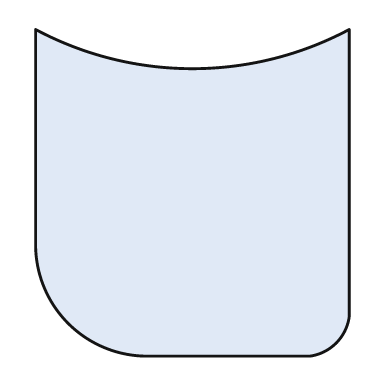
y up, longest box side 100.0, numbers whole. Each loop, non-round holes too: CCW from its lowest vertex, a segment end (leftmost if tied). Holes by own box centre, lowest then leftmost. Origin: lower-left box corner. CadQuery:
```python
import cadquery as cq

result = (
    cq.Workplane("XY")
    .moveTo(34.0, 0.0)
    .lineTo(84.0, 0.0)
    .threePointArc((92.0, 4.0), (96.0, 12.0))
    .lineTo(96.0, 100.0)
    .threePointArc((48.0, 88.0), (0.0, 100.0))
    .lineTo(0.0, 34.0)
    .threePointArc((10.0, 10.0), (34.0, 0.0))
    .close()
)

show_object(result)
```